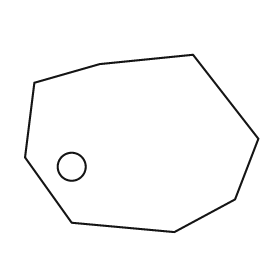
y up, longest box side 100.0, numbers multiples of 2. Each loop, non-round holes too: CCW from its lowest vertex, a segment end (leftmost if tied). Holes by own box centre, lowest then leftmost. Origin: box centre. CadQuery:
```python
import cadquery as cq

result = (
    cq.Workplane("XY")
    .moveTo(14.0, -38.0)
    .lineTo(40.0, -24.0)
    .lineTo(50.0, 2.0)
    .lineTo(22.0, 38.0)
    .lineTo(-18.0, 34.0)
    .lineTo(-46.0, 26.0)
    .lineTo(-50.0, -6.0)
    .lineTo(-30.0, -34.0)
    .close()
    .moveTo(-30.0, -10.0)
    .circle(6.0)
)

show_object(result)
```